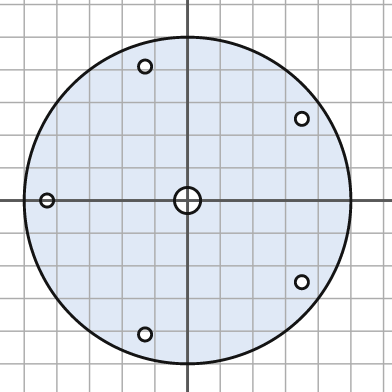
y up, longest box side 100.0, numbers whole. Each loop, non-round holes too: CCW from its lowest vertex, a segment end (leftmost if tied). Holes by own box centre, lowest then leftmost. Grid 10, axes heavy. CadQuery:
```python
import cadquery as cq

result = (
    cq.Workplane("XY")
    .moveTo(0.0, 0.0)
    .circle(50.0)
    .moveTo(-13.0, -41.0)
    .circle(2.0)
    .moveTo(35.0, -25.0)
    .circle(2.0)
    .moveTo(-43.0, 0.0)
    .circle(2.0)
    .moveTo(0.0, 0.0)
    .circle(4.0)
    .moveTo(35.0, 25.0)
    .circle(2.0)
    .moveTo(-13.0, 41.0)
    .circle(2.0)
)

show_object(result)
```